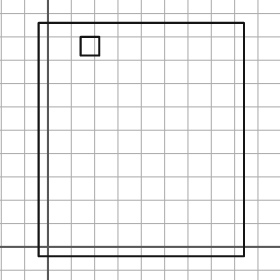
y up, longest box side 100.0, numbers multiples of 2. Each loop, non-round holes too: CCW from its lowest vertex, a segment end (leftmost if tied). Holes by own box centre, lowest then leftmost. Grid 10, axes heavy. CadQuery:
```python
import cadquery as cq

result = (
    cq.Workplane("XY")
    .moveTo(-4.0, -4.0)
    .lineTo(84.0, -4.0)
    .lineTo(84.0, 96.0)
    .lineTo(-4.0, 96.0)
    .close()
    .moveTo(14.0, 82.0)
    .lineTo(22.0, 82.0)
    .lineTo(22.0, 90.0)
    .lineTo(14.0, 90.0)
    .close()
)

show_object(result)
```